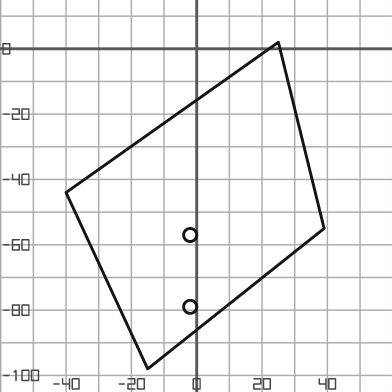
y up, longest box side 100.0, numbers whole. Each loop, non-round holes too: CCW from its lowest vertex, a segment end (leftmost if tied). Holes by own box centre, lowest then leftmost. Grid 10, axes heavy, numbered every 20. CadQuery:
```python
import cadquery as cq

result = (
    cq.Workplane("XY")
    .moveTo(-15.0, -98.0)
    .lineTo(39.0, -55.0)
    .lineTo(25.0, 2.0)
    .lineTo(-40.0, -44.0)
    .close()
    .moveTo(-2.0, -79.0)
    .circle(2.0)
    .moveTo(-2.0, -57.0)
    .circle(2.0)
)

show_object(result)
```